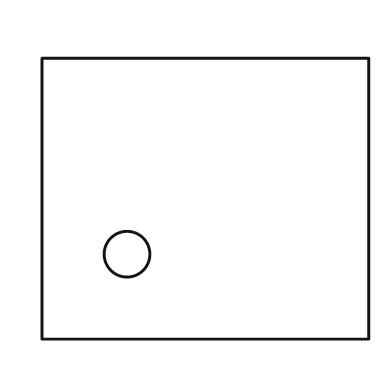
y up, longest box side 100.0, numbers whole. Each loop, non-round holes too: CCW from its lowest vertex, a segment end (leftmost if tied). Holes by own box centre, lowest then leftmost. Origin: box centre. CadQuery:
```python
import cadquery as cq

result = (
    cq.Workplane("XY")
    .moveTo(-50.0, -43.0)
    .lineTo(50.0, -43.0)
    .lineTo(50.0, 43.0)
    .lineTo(-50.0, 43.0)
    .close()
    .moveTo(-24.0, -17.0)
    .circle(7.0)
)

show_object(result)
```